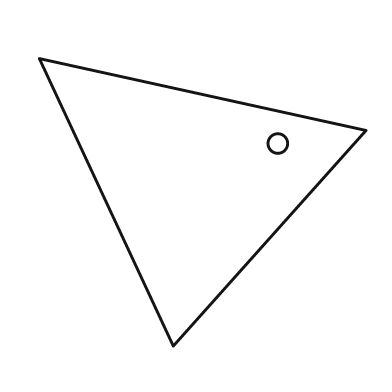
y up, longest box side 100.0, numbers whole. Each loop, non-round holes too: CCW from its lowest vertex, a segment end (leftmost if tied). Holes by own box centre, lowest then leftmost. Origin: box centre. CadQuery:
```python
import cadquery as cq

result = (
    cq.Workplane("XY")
    .moveTo(-9.0, -44.0)
    .lineTo(50.0, 22.0)
    .lineTo(-50.0, 44.0)
    .close()
    .moveTo(23.0, 18.0)
    .circle(3.0)
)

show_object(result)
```